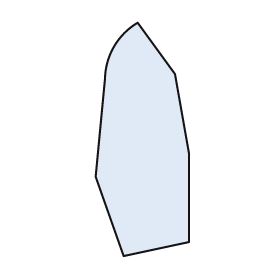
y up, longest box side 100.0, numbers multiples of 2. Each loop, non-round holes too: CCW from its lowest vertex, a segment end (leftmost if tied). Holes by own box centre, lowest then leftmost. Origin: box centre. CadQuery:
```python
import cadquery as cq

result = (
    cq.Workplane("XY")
    .moveTo(-8.0, -50.0)
    .lineTo(20.0, -44.0)
    .lineTo(20.0, -6.0)
    .lineTo(14.0, 28.0)
    .lineTo(-2.0, 50.0)
    .threePointArc((-12.0, 40.0), (-16.0, 26.0))
    .lineTo(-20.0, -16.0)
    .close()
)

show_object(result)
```